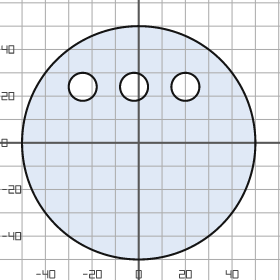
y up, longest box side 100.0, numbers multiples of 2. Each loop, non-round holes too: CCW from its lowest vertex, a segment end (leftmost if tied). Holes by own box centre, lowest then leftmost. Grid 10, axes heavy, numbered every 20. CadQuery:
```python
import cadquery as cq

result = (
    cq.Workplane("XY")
    .moveTo(0.0, 0.0)
    .circle(50.0)
    .moveTo(-24.0, 24.0)
    .circle(6.0)
    .moveTo(-2.0, 24.0)
    .circle(6.0)
    .moveTo(20.0, 24.0)
    .circle(6.0)
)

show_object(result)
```